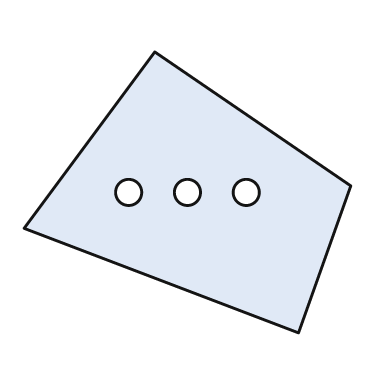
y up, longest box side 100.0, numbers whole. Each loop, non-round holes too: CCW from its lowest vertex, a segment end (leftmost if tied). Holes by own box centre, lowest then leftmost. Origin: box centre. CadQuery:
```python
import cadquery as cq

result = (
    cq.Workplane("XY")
    .moveTo(34.0, -43.0)
    .lineTo(50.0, 2.0)
    .lineTo(-10.0, 43.0)
    .lineTo(-50.0, -11.0)
    .close()
    .moveTo(-18.0, 0.0)
    .circle(4.0)
    .moveTo(0.0, 0.0)
    .circle(4.0)
    .moveTo(18.0, 0.0)
    .circle(4.0)
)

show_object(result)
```